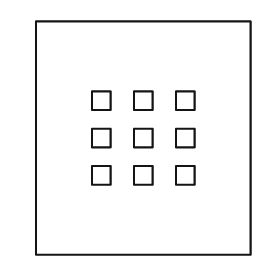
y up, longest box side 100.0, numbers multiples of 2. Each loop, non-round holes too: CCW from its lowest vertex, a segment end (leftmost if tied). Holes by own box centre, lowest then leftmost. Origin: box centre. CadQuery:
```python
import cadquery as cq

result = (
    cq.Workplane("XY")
    .moveTo(-46.0, -50.0)
    .lineTo(46.0, -50.0)
    .lineTo(46.0, 50.0)
    .lineTo(-46.0, 50.0)
    .close()
    .moveTo(-22.0, -20.0)
    .lineTo(-14.0, -20.0)
    .lineTo(-14.0, -12.0)
    .lineTo(-22.0, -12.0)
    .close()
    .moveTo(-4.0, -20.0)
    .lineTo(4.0, -20.0)
    .lineTo(4.0, -12.0)
    .lineTo(-4.0, -12.0)
    .close()
    .moveTo(14.0, -20.0)
    .lineTo(22.0, -20.0)
    .lineTo(22.0, -12.0)
    .lineTo(14.0, -12.0)
    .close()
    .moveTo(-22.0, -4.0)
    .lineTo(-14.0, -4.0)
    .lineTo(-14.0, 4.0)
    .lineTo(-22.0, 4.0)
    .close()
    .moveTo(-4.0, -4.0)
    .lineTo(4.0, -4.0)
    .lineTo(4.0, 4.0)
    .lineTo(-4.0, 4.0)
    .close()
    .moveTo(14.0, -4.0)
    .lineTo(22.0, -4.0)
    .lineTo(22.0, 4.0)
    .lineTo(14.0, 4.0)
    .close()
    .moveTo(-22.0, 12.0)
    .lineTo(-14.0, 12.0)
    .lineTo(-14.0, 20.0)
    .lineTo(-22.0, 20.0)
    .close()
    .moveTo(-4.0, 12.0)
    .lineTo(4.0, 12.0)
    .lineTo(4.0, 20.0)
    .lineTo(-4.0, 20.0)
    .close()
    .moveTo(14.0, 12.0)
    .lineTo(22.0, 12.0)
    .lineTo(22.0, 20.0)
    .lineTo(14.0, 20.0)
    .close()
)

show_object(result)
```